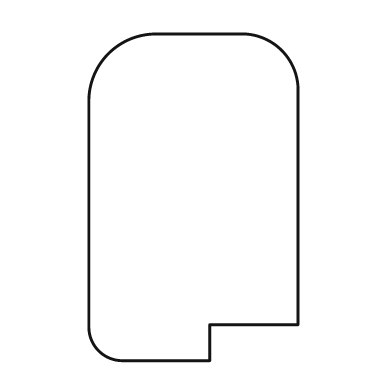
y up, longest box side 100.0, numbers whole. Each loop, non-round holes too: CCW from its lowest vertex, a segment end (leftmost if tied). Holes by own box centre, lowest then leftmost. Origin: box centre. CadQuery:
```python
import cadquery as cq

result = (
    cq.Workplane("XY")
    .moveTo(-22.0, -50.0)
    .lineTo(5.0, -50.0)
    .lineTo(5.0, -39.0)
    .lineTo(32.0, -39.0)
    .lineTo(32.0, 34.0)
    .threePointArc((27.0, 45.0), (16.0, 50.0))
    .lineTo(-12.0, 50.0)
    .threePointArc((-26.0, 44.0), (-32.0, 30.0))
    .lineTo(-32.0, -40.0)
    .threePointArc((-29.0, -47.0), (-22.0, -50.0))
    .close()
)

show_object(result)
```